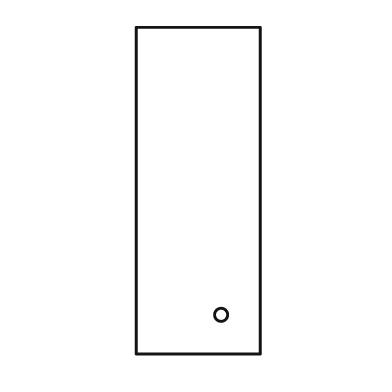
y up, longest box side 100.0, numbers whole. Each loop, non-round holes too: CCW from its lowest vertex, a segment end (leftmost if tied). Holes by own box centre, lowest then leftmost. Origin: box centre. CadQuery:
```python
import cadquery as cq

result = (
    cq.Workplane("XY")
    .moveTo(-19.0, -50.0)
    .lineTo(19.0, -50.0)
    .lineTo(19.0, 50.0)
    .lineTo(-19.0, 50.0)
    .close()
    .moveTo(7.0, -38.0)
    .circle(2.0)
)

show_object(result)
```